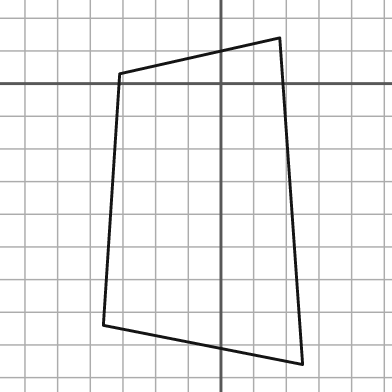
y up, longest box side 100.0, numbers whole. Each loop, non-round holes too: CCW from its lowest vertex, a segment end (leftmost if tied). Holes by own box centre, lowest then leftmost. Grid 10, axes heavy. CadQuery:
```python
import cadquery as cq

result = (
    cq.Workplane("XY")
    .moveTo(25.0, -86.0)
    .lineTo(18.0, 14.0)
    .lineTo(-31.0, 3.0)
    .lineTo(-36.0, -74.0)
    .close()
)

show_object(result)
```